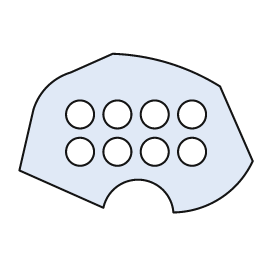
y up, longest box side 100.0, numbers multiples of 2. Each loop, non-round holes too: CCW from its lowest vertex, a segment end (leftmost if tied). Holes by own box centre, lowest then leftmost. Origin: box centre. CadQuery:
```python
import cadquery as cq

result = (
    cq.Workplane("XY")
    .moveTo(16.0, -34.0)
    .threePointArc((36.0, -28.0), (50.0, -12.0))
    .lineTo(36.0, 20.0)
    .threePointArc((14.0, 30.0), (-10.0, 34.0))
    .lineTo(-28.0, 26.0)
    .threePointArc((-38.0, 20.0), (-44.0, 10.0))
    .lineTo(-50.0, -16.0)
    .lineTo(-14.0, -32.0)
    .threePointArc((2.0, -20.0), (16.0, -34.0))
    .close()
    .moveTo(-24.0, -8.0)
    .circle(6.0)
    .moveTo(-8.0, -8.0)
    .circle(6.0)
    .moveTo(8.0, -8.0)
    .circle(6.0)
    .moveTo(24.0, -8.0)
    .circle(6.0)
    .moveTo(-24.0, 8.0)
    .circle(6.0)
    .moveTo(-8.0, 8.0)
    .circle(6.0)
    .moveTo(8.0, 8.0)
    .circle(6.0)
    .moveTo(24.0, 8.0)
    .circle(6.0)
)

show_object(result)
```